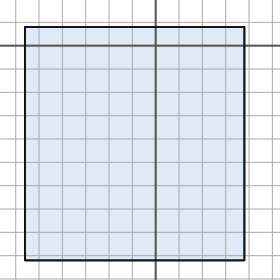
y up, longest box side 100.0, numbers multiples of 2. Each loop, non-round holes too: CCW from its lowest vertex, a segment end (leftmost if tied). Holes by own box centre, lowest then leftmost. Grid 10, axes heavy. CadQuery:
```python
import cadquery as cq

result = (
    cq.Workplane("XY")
    .moveTo(-56.0, -92.0)
    .lineTo(38.0, -92.0)
    .lineTo(38.0, 8.0)
    .lineTo(-56.0, 8.0)
    .close()
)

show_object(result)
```